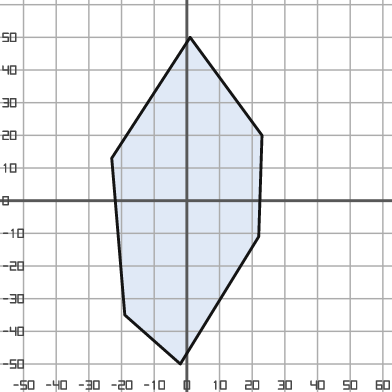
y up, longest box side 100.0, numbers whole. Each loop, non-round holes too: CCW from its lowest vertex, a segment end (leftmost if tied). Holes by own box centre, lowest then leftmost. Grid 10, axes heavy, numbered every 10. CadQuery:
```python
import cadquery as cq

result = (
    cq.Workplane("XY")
    .moveTo(-2.0, -50.0)
    .lineTo(22.0, -11.0)
    .lineTo(23.0, 20.0)
    .lineTo(1.0, 50.0)
    .lineTo(-23.0, 13.0)
    .lineTo(-19.0, -35.0)
    .close()
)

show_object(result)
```